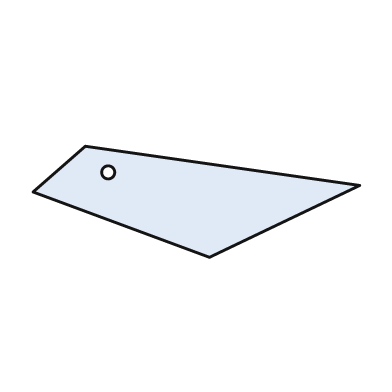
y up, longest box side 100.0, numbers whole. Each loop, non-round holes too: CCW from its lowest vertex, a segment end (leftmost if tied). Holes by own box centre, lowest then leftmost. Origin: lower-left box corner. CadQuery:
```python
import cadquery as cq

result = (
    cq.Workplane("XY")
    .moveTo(54.0, 0.0)
    .lineTo(100.0, 22.0)
    .lineTo(16.0, 34.0)
    .lineTo(0.0, 20.0)
    .close()
    .moveTo(23.0, 26.0)
    .circle(2.0)
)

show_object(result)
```